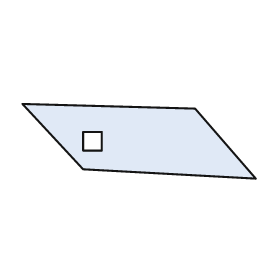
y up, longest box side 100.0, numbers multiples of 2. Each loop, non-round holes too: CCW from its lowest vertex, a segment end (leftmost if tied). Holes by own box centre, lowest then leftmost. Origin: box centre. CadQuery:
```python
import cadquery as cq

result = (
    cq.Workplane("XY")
    .moveTo(50.0, -16.0)
    .lineTo(24.0, 14.0)
    .lineTo(-50.0, 16.0)
    .lineTo(-24.0, -12.0)
    .close()
    .moveTo(-24.0, -4.0)
    .lineTo(-16.0, -4.0)
    .lineTo(-16.0, 4.0)
    .lineTo(-24.0, 4.0)
    .close()
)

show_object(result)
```